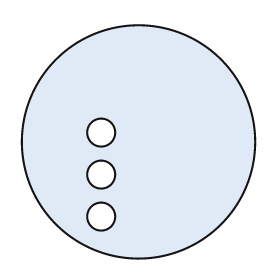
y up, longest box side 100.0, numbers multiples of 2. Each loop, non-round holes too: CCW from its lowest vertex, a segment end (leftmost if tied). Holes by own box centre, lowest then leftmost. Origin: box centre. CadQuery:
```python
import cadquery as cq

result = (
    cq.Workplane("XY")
    .moveTo(0.0, 0.0)
    .circle(50.0)
    .moveTo(-16.0, -32.0)
    .circle(6.0)
    .moveTo(-16.0, -14.0)
    .circle(6.0)
    .moveTo(-16.0, 4.0)
    .circle(6.0)
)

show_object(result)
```